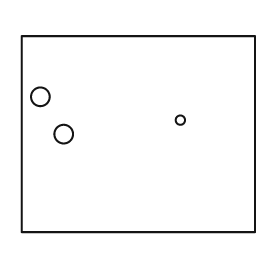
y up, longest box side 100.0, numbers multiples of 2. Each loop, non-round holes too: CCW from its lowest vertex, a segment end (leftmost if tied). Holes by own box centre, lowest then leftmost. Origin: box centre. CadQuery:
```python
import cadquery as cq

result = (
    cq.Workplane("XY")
    .moveTo(-50.0, -42.0)
    .lineTo(50.0, -42.0)
    .lineTo(50.0, 42.0)
    .lineTo(-50.0, 42.0)
    .close()
    .moveTo(-32.0, 0.0)
    .circle(4.0)
    .moveTo(18.0, 6.0)
    .circle(2.0)
    .moveTo(-42.0, 16.0)
    .circle(4.0)
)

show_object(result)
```